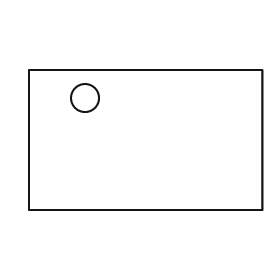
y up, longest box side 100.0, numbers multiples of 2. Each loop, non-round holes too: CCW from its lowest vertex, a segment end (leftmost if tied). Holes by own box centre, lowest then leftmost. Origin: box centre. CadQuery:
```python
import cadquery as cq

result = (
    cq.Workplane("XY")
    .moveTo(-50.0, -30.0)
    .lineTo(50.0, -30.0)
    .lineTo(50.0, 30.0)
    .lineTo(-50.0, 30.0)
    .close()
    .moveTo(-26.0, 18.0)
    .circle(6.0)
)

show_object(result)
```